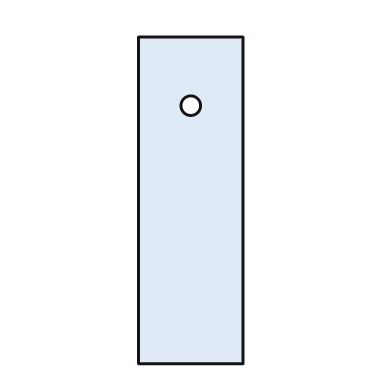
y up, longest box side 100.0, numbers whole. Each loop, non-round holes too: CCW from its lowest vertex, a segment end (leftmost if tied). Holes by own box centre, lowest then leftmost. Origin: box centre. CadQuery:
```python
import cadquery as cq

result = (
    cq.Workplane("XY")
    .moveTo(-16.0, -50.0)
    .lineTo(16.0, -50.0)
    .lineTo(16.0, 50.0)
    .lineTo(-16.0, 50.0)
    .close()
    .moveTo(0.0, 29.0)
    .circle(3.0)
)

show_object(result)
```